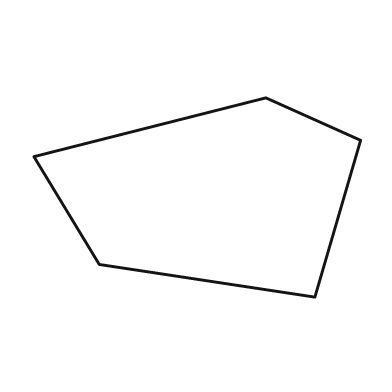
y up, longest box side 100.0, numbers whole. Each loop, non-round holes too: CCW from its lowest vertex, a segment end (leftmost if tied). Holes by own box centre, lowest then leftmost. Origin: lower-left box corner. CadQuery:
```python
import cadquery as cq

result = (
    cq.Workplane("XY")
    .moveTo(86.0, 0.0)
    .lineTo(100.0, 48.0)
    .lineTo(71.0, 61.0)
    .lineTo(0.0, 43.0)
    .lineTo(20.0, 10.0)
    .close()
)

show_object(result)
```